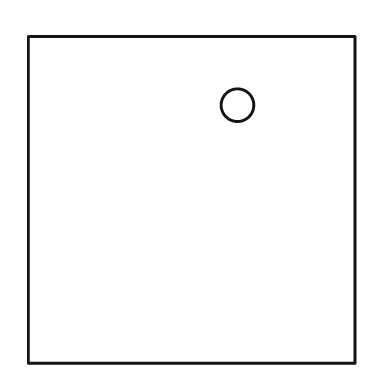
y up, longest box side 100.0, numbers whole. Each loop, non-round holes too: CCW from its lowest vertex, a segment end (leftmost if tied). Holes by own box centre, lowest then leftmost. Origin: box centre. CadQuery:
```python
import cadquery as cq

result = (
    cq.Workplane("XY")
    .moveTo(-50.0, -50.0)
    .lineTo(50.0, -50.0)
    .lineTo(50.0, 50.0)
    .lineTo(-50.0, 50.0)
    .close()
    .moveTo(14.0, 29.0)
    .circle(5.0)
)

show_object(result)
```